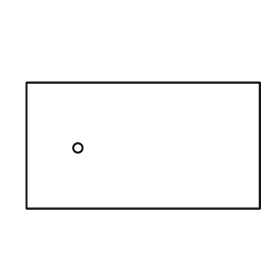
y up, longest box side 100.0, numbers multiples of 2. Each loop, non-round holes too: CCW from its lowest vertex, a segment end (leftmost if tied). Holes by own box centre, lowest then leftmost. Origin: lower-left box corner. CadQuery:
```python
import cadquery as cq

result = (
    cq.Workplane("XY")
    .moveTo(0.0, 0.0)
    .lineTo(100.0, 0.0)
    .lineTo(100.0, 54.0)
    .lineTo(0.0, 54.0)
    .close()
    .moveTo(22.0, 26.0)
    .circle(2.0)
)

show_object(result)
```